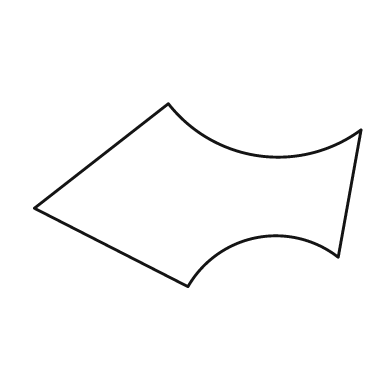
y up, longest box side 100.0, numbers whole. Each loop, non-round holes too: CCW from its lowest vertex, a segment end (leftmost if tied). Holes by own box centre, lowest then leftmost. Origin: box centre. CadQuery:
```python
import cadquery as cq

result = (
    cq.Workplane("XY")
    .moveTo(-3.0, -28.0)
    .threePointArc((18.0, -13.0), (43.0, -19.0))
    .lineTo(50.0, 20.0)
    .threePointArc((19.0, 12.0), (-9.0, 28.0))
    .lineTo(-50.0, -4.0)
    .close()
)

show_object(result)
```